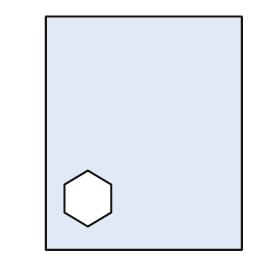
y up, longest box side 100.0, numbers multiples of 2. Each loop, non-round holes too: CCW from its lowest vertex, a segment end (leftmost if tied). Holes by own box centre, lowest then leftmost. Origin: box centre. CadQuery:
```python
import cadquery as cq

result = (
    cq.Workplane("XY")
    .moveTo(-42.0, -50.0)
    .lineTo(42.0, -50.0)
    .lineTo(42.0, 50.0)
    .lineTo(-42.0, 50.0)
    .close()
    .moveTo(-24.0, -40.0)
    .lineTo(-14.0, -34.0)
    .lineTo(-14.0, -22.0)
    .lineTo(-24.0, -16.0)
    .lineTo(-34.0, -22.0)
    .lineTo(-34.0, -34.0)
    .close()
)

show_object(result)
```